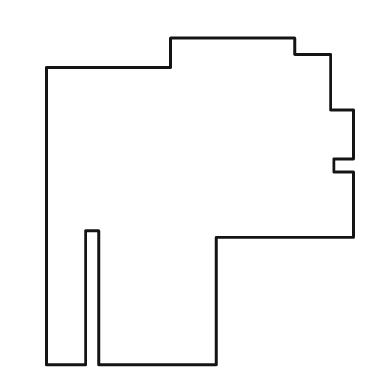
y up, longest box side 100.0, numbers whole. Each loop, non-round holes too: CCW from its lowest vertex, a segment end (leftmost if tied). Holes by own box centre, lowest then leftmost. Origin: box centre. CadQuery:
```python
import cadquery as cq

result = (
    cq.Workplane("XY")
    .moveTo(-47.0, -50.0)
    .lineTo(-35.0, -50.0)
    .lineTo(-35.0, -9.0)
    .lineTo(-31.0, -9.0)
    .lineTo(-31.0, -50.0)
    .lineTo(5.0, -50.0)
    .lineTo(5.0, -11.0)
    .lineTo(47.0, -11.0)
    .lineTo(47.0, 9.0)
    .lineTo(41.0, 9.0)
    .lineTo(41.0, 13.0)
    .lineTo(47.0, 13.0)
    .lineTo(47.0, 28.0)
    .lineTo(40.0, 28.0)
    .lineTo(40.0, 45.0)
    .lineTo(29.0, 45.0)
    .lineTo(29.0, 50.0)
    .lineTo(-9.0, 50.0)
    .lineTo(-9.0, 41.0)
    .lineTo(-47.0, 41.0)
    .close()
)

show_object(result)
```